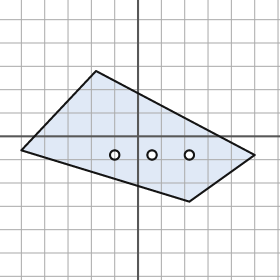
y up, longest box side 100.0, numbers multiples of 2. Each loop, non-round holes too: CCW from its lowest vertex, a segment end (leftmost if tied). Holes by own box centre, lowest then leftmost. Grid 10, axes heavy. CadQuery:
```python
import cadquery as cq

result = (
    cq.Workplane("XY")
    .moveTo(22.0, -28.0)
    .lineTo(50.0, -8.0)
    .lineTo(-18.0, 28.0)
    .lineTo(-50.0, -6.0)
    .close()
    .moveTo(-10.0, -8.0)
    .circle(2.0)
    .moveTo(6.0, -8.0)
    .circle(2.0)
    .moveTo(22.0, -8.0)
    .circle(2.0)
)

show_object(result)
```